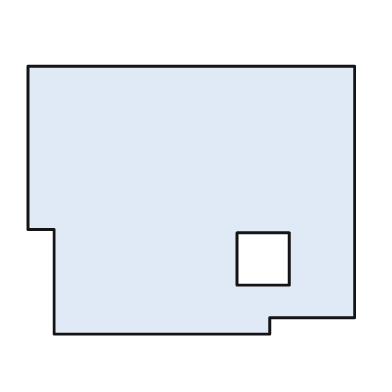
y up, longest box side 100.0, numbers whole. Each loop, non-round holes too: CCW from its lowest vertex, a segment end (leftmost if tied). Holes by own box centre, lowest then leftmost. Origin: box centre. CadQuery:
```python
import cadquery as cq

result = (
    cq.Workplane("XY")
    .moveTo(-42.0, -41.0)
    .lineTo(24.0, -41.0)
    .lineTo(24.0, -36.0)
    .lineTo(50.0, -36.0)
    .lineTo(50.0, 41.0)
    .lineTo(-50.0, 41.0)
    .lineTo(-50.0, -9.0)
    .lineTo(-42.0, -9.0)
    .close()
    .moveTo(14.0, -26.0)
    .lineTo(30.0, -26.0)
    .lineTo(30.0, -10.0)
    .lineTo(14.0, -10.0)
    .close()
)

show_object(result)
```